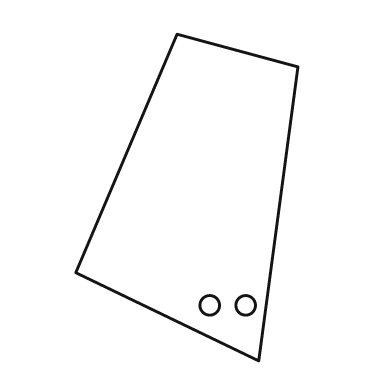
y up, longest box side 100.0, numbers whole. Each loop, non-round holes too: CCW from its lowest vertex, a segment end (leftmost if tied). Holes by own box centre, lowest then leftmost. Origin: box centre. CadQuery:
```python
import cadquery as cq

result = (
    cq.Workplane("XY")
    .moveTo(22.0, -50.0)
    .lineTo(34.0, 40.0)
    .lineTo(-3.0, 50.0)
    .lineTo(-34.0, -23.0)
    .close()
    .moveTo(7.0, -33.0)
    .circle(3.0)
    .moveTo(18.0, -33.0)
    .circle(3.0)
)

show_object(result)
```